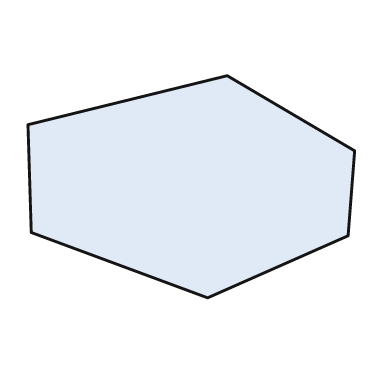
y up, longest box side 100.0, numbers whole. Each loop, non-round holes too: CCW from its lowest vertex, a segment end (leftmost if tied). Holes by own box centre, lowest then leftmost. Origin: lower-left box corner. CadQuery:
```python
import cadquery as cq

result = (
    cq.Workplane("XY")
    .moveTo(55.0, 0.0)
    .lineTo(98.0, 19.0)
    .lineTo(100.0, 45.0)
    .lineTo(61.0, 68.0)
    .lineTo(0.0, 53.0)
    .lineTo(1.0, 20.0)
    .close()
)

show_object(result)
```